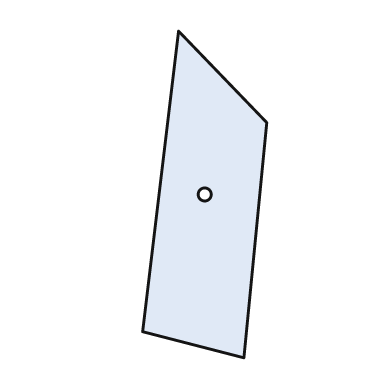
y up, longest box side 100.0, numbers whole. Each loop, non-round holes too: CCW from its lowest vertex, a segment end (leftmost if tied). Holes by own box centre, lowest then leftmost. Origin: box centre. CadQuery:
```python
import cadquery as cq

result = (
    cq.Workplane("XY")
    .moveTo(12.0, -50.0)
    .lineTo(19.0, 22.0)
    .lineTo(-8.0, 50.0)
    .lineTo(-19.0, -42.0)
    .close()
    .moveTo(0.0, 0.0)
    .circle(2.0)
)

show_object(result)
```